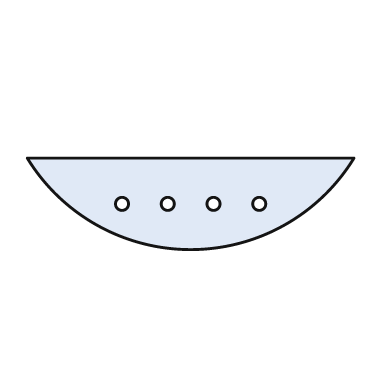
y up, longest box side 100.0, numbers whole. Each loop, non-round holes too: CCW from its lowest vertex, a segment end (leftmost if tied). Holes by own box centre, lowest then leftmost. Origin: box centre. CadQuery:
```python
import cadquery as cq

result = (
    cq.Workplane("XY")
    .moveTo(-50.0, 14.0)
    .threePointArc((0.0, -14.0), (50.0, 14.0))
    .close()
    .moveTo(-21.0, 0.0)
    .circle(2.0)
    .moveTo(-7.0, 0.0)
    .circle(2.0)
    .moveTo(7.0, 0.0)
    .circle(2.0)
    .moveTo(21.0, 0.0)
    .circle(2.0)
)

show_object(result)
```